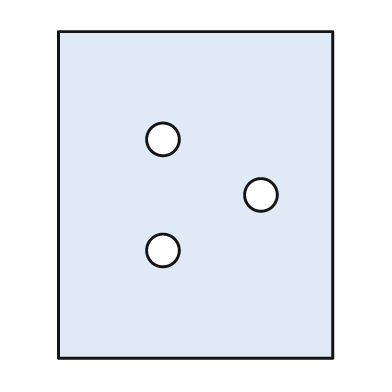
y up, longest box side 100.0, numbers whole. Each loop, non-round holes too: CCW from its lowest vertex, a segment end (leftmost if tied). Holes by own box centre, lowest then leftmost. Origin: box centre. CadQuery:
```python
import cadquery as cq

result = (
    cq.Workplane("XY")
    .moveTo(-42.0, -50.0)
    .lineTo(42.0, -50.0)
    .lineTo(42.0, 50.0)
    .lineTo(-42.0, 50.0)
    .close()
    .moveTo(-10.0, -17.0)
    .circle(5.0)
    .moveTo(20.0, 0.0)
    .circle(5.0)
    .moveTo(-10.0, 17.0)
    .circle(5.0)
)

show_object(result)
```